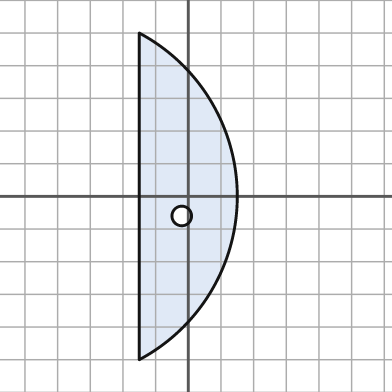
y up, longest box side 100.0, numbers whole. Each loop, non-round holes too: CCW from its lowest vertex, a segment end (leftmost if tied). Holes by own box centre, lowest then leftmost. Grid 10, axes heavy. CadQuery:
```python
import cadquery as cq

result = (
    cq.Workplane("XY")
    .moveTo(-15.0, -50.0)
    .threePointArc((15.0, 0.0), (-15.0, 50.0))
    .close()
    .moveTo(-2.0, -6.0)
    .circle(3.0)
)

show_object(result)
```